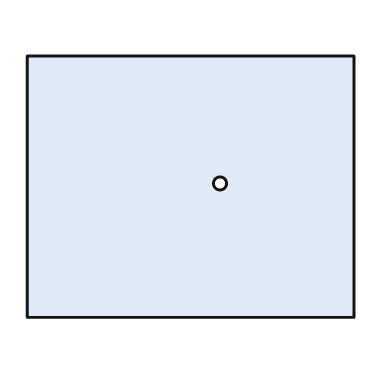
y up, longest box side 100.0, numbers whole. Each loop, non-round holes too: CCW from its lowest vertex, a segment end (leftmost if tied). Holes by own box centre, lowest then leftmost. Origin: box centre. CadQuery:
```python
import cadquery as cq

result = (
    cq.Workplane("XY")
    .moveTo(-50.0, -40.0)
    .lineTo(50.0, -40.0)
    .lineTo(50.0, 40.0)
    .lineTo(-50.0, 40.0)
    .close()
    .moveTo(9.0, 1.0)
    .circle(2.0)
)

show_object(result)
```